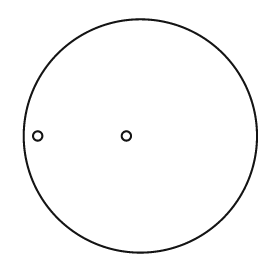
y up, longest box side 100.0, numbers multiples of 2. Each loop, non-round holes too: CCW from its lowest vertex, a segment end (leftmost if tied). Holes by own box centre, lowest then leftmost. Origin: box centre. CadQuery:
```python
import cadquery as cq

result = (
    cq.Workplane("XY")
    .moveTo(0.0, 0.0)
    .circle(50.0)
    .moveTo(-44.0, 0.0)
    .circle(2.0)
    .moveTo(-6.0, 0.0)
    .circle(2.0)
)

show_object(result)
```